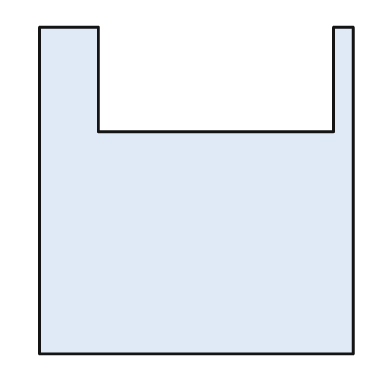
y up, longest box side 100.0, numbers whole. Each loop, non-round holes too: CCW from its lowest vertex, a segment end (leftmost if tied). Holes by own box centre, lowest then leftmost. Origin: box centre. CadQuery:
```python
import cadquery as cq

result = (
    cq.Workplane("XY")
    .moveTo(-48.0, -50.0)
    .lineTo(48.0, -50.0)
    .lineTo(48.0, 50.0)
    .lineTo(42.0, 50.0)
    .lineTo(42.0, 18.0)
    .lineTo(-30.0, 18.0)
    .lineTo(-30.0, 50.0)
    .lineTo(-48.0, 50.0)
    .close()
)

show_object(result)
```